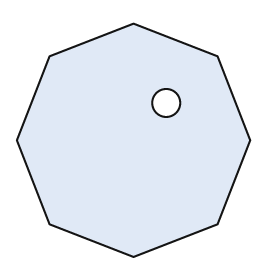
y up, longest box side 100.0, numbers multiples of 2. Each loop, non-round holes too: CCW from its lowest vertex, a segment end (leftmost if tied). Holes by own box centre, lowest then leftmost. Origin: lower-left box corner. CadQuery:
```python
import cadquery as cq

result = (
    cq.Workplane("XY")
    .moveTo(50.0, 0.0)
    .lineTo(86.0, 14.0)
    .lineTo(100.0, 50.0)
    .lineTo(86.0, 86.0)
    .lineTo(50.0, 100.0)
    .lineTo(14.0, 86.0)
    .lineTo(0.0, 50.0)
    .lineTo(14.0, 14.0)
    .close()
    .moveTo(64.0, 66.0)
    .circle(6.0)
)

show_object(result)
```